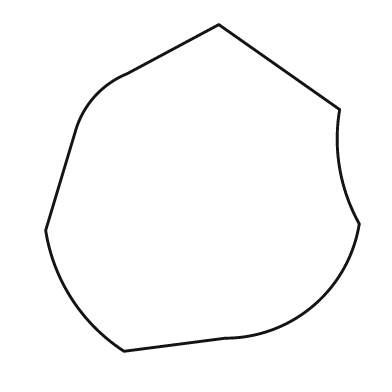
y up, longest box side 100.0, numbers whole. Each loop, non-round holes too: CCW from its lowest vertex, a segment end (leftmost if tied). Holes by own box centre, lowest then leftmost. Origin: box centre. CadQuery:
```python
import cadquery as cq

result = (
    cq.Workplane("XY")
    .moveTo(-24.0, -50.0)
    .lineTo(7.0, -46.0)
    .threePointArc((34.0, -36.0), (48.0, -11.0))
    .threePointArc((42.0, 6.0), (42.0, 24.0))
    .lineTo(5.0, 50.0)
    .lineTo(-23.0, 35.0)
    .threePointArc((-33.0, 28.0), (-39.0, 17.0))
    .lineTo(-48.0, -13.0)
    .threePointArc((-40.0, -34.0), (-24.0, -50.0))
    .close()
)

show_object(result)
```